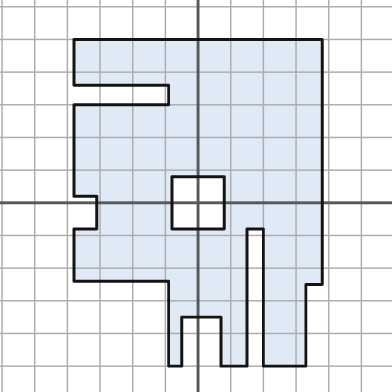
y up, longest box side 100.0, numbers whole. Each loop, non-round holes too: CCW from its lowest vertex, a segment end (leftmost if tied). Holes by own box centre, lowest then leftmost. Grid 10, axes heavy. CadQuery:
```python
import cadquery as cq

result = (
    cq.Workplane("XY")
    .moveTo(-9.0, -50.0)
    .lineTo(-5.0, -50.0)
    .lineTo(-5.0, -35.0)
    .lineTo(7.0, -35.0)
    .lineTo(7.0, -50.0)
    .lineTo(15.0, -50.0)
    .lineTo(15.0, -8.0)
    .lineTo(20.0, -8.0)
    .lineTo(20.0, -50.0)
    .lineTo(33.0, -50.0)
    .lineTo(33.0, -25.0)
    .lineTo(38.0, -25.0)
    .lineTo(38.0, 50.0)
    .lineTo(-38.0, 50.0)
    .lineTo(-38.0, 36.0)
    .lineTo(-9.0, 36.0)
    .lineTo(-9.0, 30.0)
    .lineTo(-38.0, 30.0)
    .lineTo(-38.0, 2.0)
    .lineTo(-31.0, 2.0)
    .lineTo(-31.0, -8.0)
    .lineTo(-38.0, -8.0)
    .lineTo(-38.0, -24.0)
    .lineTo(-9.0, -24.0)
    .close()
    .moveTo(-8.0, -8.0)
    .lineTo(8.0, -8.0)
    .lineTo(8.0, 8.0)
    .lineTo(-8.0, 8.0)
    .close()
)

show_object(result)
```